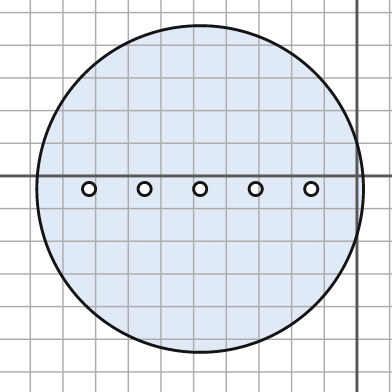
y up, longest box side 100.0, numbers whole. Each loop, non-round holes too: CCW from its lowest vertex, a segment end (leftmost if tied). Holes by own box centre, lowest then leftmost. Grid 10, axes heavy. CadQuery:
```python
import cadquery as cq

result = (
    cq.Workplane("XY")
    .moveTo(-48.0, -4.0)
    .circle(50.0)
    .moveTo(-82.0, -4.0)
    .circle(2.0)
    .moveTo(-65.0, -4.0)
    .circle(2.0)
    .moveTo(-48.0, -4.0)
    .circle(2.0)
    .moveTo(-31.0, -4.0)
    .circle(2.0)
    .moveTo(-14.0, -4.0)
    .circle(2.0)
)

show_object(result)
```